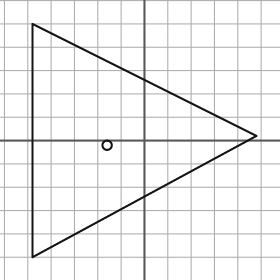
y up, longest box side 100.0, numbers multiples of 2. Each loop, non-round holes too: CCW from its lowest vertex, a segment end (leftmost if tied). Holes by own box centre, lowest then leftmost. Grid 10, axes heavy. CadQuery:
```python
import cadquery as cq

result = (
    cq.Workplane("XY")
    .moveTo(-48.0, -50.0)
    .lineTo(48.0, 2.0)
    .lineTo(-48.0, 50.0)
    .close()
    .moveTo(-16.0, -2.0)
    .circle(2.0)
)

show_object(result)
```